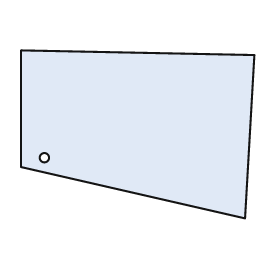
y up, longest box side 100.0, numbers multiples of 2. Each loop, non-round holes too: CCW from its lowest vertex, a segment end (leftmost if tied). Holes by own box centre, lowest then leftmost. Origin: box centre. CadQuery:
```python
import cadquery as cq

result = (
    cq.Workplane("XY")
    .moveTo(46.0, -36.0)
    .lineTo(50.0, 34.0)
    .lineTo(-50.0, 36.0)
    .lineTo(-50.0, -14.0)
    .close()
    .moveTo(-40.0, -10.0)
    .circle(2.0)
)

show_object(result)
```